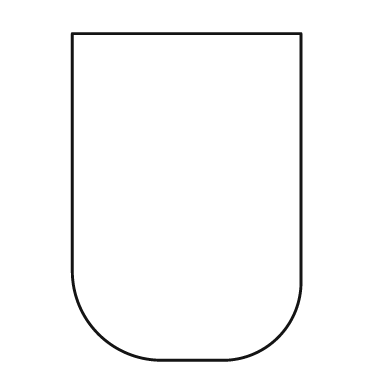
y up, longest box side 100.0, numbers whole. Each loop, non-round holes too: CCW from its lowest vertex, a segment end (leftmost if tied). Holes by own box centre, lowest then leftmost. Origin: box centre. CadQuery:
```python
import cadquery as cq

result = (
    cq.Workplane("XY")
    .moveTo(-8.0, -50.0)
    .lineTo(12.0, -50.0)
    .threePointArc((28.0, -43.0), (35.0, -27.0))
    .lineTo(35.0, 50.0)
    .lineTo(-35.0, 50.0)
    .lineTo(-35.0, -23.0)
    .threePointArc((-27.0, -42.0), (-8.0, -50.0))
    .close()
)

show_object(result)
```